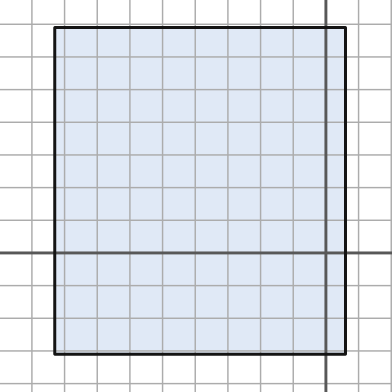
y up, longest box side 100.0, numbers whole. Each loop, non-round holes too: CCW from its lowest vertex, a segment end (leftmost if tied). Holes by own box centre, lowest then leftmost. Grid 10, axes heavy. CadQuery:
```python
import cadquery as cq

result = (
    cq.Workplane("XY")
    .moveTo(-83.0, -31.0)
    .lineTo(6.0, -31.0)
    .lineTo(6.0, 69.0)
    .lineTo(-83.0, 69.0)
    .close()
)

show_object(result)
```